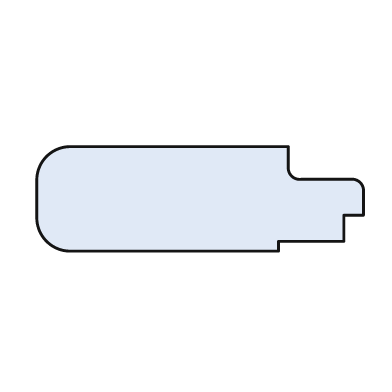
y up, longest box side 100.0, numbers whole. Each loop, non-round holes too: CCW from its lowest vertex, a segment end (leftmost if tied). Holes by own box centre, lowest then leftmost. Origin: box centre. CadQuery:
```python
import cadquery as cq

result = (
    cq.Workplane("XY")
    .moveTo(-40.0, -16.0)
    .lineTo(24.0, -16.0)
    .lineTo(24.0, -13.0)
    .lineTo(44.0, -13.0)
    .lineTo(44.0, -5.0)
    .lineTo(50.0, -5.0)
    .lineTo(50.0, 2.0)
    .threePointArc((49.0, 5.0), (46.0, 6.0))
    .lineTo(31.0, 6.0)
    .threePointArc((28.0, 7.0), (27.0, 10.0))
    .lineTo(27.0, 16.0)
    .lineTo(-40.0, 16.0)
    .threePointArc((-47.0, 13.0), (-50.0, 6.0))
    .lineTo(-50.0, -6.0)
    .threePointArc((-47.0, -13.0), (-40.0, -16.0))
    .close()
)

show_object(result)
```